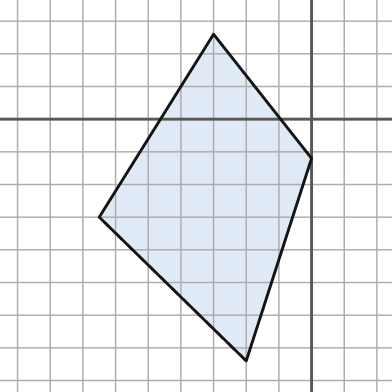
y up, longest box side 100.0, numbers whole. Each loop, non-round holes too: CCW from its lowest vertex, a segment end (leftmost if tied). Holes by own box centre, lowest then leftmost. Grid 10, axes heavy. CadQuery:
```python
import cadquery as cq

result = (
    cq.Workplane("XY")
    .moveTo(-20.0, -74.0)
    .lineTo(0.0, -12.0)
    .lineTo(-30.0, 26.0)
    .lineTo(-65.0, -30.0)
    .close()
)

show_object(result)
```